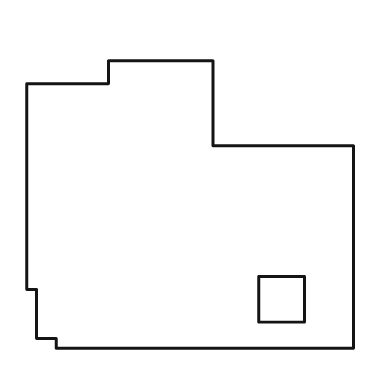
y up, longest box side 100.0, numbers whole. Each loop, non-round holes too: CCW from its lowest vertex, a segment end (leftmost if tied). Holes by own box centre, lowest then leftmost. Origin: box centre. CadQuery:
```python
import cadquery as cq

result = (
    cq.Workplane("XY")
    .moveTo(-41.0, -44.0)
    .lineTo(50.0, -44.0)
    .lineTo(50.0, 18.0)
    .lineTo(7.0, 18.0)
    .lineTo(7.0, 44.0)
    .lineTo(-25.0, 44.0)
    .lineTo(-25.0, 37.0)
    .lineTo(-50.0, 37.0)
    .lineTo(-50.0, -26.0)
    .lineTo(-47.0, -26.0)
    .lineTo(-47.0, -41.0)
    .lineTo(-41.0, -41.0)
    .close()
    .moveTo(21.0, -36.0)
    .lineTo(35.0, -36.0)
    .lineTo(35.0, -22.0)
    .lineTo(21.0, -22.0)
    .close()
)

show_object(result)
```